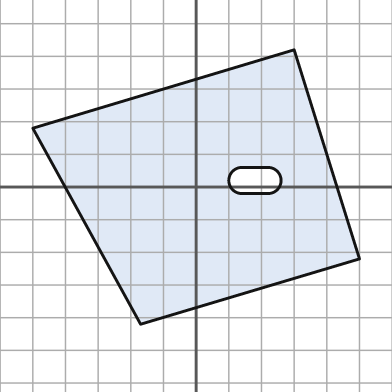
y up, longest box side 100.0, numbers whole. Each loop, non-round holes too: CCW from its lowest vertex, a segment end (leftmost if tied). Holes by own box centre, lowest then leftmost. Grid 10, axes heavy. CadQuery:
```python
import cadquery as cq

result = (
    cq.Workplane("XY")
    .moveTo(-17.0, -42.0)
    .lineTo(50.0, -22.0)
    .lineTo(30.0, 42.0)
    .lineTo(-50.0, 18.0)
    .close()
    .moveTo(14.0, -2.0)
    .lineTo(22.0, -2.0)
    .threePointArc((26.0, 2.0), (22.0, 6.0))
    .lineTo(14.0, 6.0)
    .threePointArc((10.0, 2.0), (14.0, -2.0))
    .close()
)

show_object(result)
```